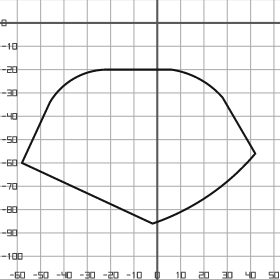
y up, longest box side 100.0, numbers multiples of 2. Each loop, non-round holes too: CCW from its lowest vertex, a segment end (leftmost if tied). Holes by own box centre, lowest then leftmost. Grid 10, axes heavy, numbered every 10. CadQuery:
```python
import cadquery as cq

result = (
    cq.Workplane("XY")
    .moveTo(-2.0, -86.0)
    .threePointArc((22.0, -74.0), (42.0, -56.0))
    .lineTo(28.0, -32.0)
    .threePointArc((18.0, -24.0), (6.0, -20.0))
    .lineTo(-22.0, -20.0)
    .threePointArc((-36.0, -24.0), (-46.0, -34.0))
    .lineTo(-58.0, -60.0)
    .close()
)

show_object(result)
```